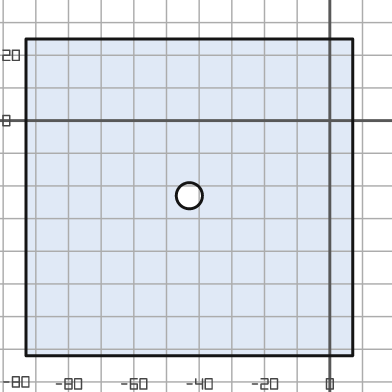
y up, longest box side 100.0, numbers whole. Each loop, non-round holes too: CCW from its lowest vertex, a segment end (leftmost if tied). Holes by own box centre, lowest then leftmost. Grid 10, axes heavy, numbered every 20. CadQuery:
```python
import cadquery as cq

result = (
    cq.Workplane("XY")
    .moveTo(-93.0, -72.0)
    .lineTo(7.0, -72.0)
    .lineTo(7.0, 25.0)
    .lineTo(-93.0, 25.0)
    .close()
    .moveTo(-43.0, -23.0)
    .circle(4.0)
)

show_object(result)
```